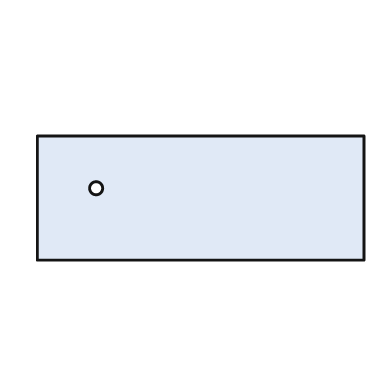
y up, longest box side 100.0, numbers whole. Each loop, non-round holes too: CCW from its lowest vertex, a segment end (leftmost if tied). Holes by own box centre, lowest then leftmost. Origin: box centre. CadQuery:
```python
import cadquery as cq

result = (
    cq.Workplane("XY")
    .moveTo(-50.0, -19.0)
    .lineTo(50.0, -19.0)
    .lineTo(50.0, 19.0)
    .lineTo(-50.0, 19.0)
    .close()
    .moveTo(-32.0, 3.0)
    .circle(2.0)
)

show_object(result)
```